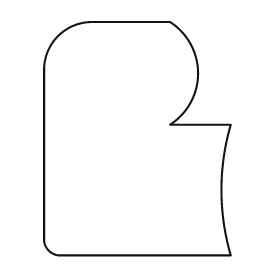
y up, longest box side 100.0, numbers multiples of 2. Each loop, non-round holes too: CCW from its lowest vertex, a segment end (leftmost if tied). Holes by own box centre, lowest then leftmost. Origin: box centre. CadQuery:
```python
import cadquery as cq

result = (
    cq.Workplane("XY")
    .moveTo(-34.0, -50.0)
    .lineTo(40.0, -50.0)
    .threePointArc((36.0, -22.0), (40.0, 6.0))
    .lineTo(14.0, 6.0)
    .threePointArc((26.0, 28.0), (14.0, 50.0))
    .lineTo(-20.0, 50.0)
    .threePointArc((-34.0, 44.0), (-40.0, 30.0))
    .lineTo(-40.0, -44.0)
    .threePointArc((-38.0, -48.0), (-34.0, -50.0))
    .close()
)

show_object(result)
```